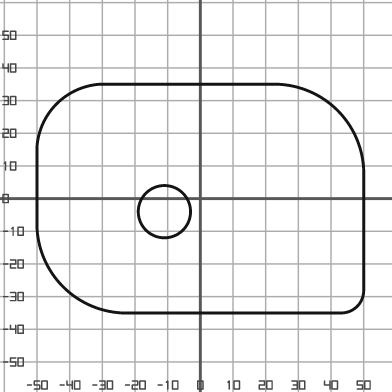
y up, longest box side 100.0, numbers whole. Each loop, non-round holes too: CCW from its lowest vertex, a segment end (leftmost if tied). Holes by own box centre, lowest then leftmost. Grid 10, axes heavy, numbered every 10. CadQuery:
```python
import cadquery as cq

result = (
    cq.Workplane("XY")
    .moveTo(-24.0, -35.0)
    .lineTo(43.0, -35.0)
    .threePointArc((48.0, -33.0), (50.0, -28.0))
    .lineTo(50.0, 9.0)
    .threePointArc((42.0, 27.0), (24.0, 35.0))
    .lineTo(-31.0, 35.0)
    .threePointArc((-44.0, 29.0), (-50.0, 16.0))
    .lineTo(-50.0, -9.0)
    .threePointArc((-42.0, -27.0), (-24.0, -35.0))
    .close()
    .moveTo(-11.0, -4.0)
    .circle(8.0)
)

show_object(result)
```